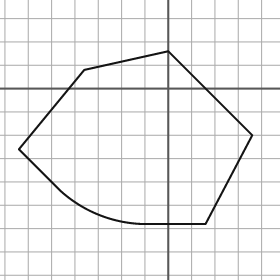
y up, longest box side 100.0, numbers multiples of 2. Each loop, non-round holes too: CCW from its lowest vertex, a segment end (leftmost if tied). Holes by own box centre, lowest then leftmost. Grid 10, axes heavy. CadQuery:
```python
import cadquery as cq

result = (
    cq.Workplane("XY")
    .moveTo(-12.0, -58.0)
    .lineTo(16.0, -58.0)
    .lineTo(36.0, -20.0)
    .lineTo(0.0, 16.0)
    .lineTo(-36.0, 8.0)
    .lineTo(-64.0, -26.0)
    .lineTo(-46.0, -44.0)
    .threePointArc((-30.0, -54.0), (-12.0, -58.0))
    .close()
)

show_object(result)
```